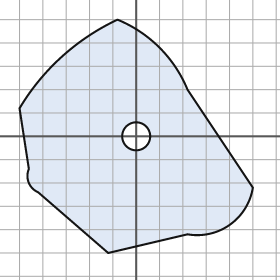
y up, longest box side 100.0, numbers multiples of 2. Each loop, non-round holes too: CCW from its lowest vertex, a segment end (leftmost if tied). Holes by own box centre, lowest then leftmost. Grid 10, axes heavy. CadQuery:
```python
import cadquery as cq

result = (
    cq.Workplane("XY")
    .moveTo(-12.0, -50.0)
    .lineTo(22.0, -42.0)
    .threePointArc((40.0, -38.0), (50.0, -22.0))
    .lineTo(22.0, 20.0)
    .threePointArc((10.0, 38.0), (-8.0, 50.0))
    .threePointArc((-32.0, 34.0), (-50.0, 12.0))
    .lineTo(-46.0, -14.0)
    .threePointArc((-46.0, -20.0), (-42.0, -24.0))
    .close()
    .moveTo(0.0, 0.0)
    .circle(6.0)
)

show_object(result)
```